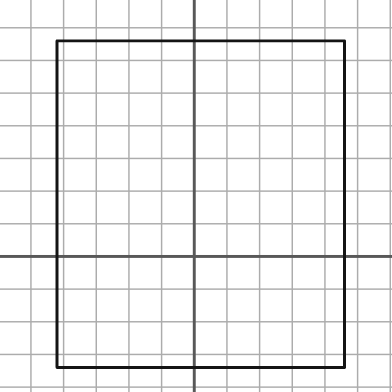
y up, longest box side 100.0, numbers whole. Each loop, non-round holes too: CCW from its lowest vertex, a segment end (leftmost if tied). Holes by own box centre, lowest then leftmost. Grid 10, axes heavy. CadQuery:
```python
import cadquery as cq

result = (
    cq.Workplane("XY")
    .moveTo(-42.0, -34.0)
    .lineTo(46.0, -34.0)
    .lineTo(46.0, 66.0)
    .lineTo(-42.0, 66.0)
    .close()
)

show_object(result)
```